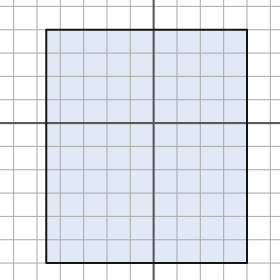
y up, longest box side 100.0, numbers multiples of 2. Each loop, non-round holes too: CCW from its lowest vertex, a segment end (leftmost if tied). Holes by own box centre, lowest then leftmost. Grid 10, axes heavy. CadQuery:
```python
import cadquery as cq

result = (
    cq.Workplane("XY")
    .moveTo(-46.0, -60.0)
    .lineTo(40.0, -60.0)
    .lineTo(40.0, 40.0)
    .lineTo(-46.0, 40.0)
    .close()
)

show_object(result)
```